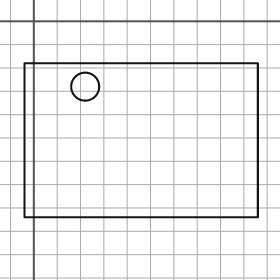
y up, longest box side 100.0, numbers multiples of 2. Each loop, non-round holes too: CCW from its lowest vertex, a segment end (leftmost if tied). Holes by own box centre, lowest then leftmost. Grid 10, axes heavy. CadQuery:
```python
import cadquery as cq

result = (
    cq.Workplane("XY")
    .moveTo(-4.0, -84.0)
    .lineTo(96.0, -84.0)
    .lineTo(96.0, -18.0)
    .lineTo(-4.0, -18.0)
    .close()
    .moveTo(22.0, -28.0)
    .circle(6.0)
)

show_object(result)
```